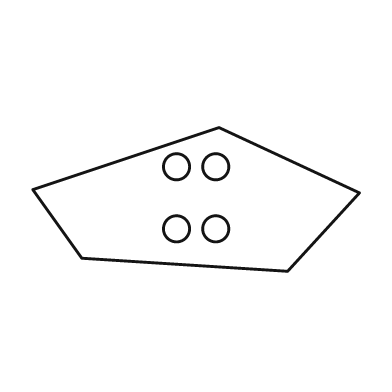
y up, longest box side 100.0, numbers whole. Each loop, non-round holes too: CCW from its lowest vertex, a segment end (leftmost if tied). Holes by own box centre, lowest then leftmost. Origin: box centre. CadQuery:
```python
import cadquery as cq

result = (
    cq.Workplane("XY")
    .moveTo(28.0, -22.0)
    .lineTo(50.0, 2.0)
    .lineTo(7.0, 22.0)
    .lineTo(-50.0, 3.0)
    .lineTo(-35.0, -18.0)
    .close()
    .moveTo(-6.0, -9.0)
    .circle(4.0)
    .moveTo(6.0, -9.0)
    .circle(4.0)
    .moveTo(-6.0, 10.0)
    .circle(4.0)
    .moveTo(6.0, 10.0)
    .circle(4.0)
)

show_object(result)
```